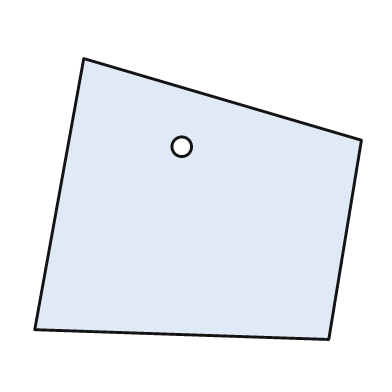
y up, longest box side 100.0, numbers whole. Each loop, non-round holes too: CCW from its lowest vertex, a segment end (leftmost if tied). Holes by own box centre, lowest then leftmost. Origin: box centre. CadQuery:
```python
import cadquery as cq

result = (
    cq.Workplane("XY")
    .moveTo(40.0, -43.0)
    .lineTo(50.0, 18.0)
    .lineTo(-35.0, 43.0)
    .lineTo(-50.0, -40.0)
    .close()
    .moveTo(-5.0, 16.0)
    .circle(3.0)
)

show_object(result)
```